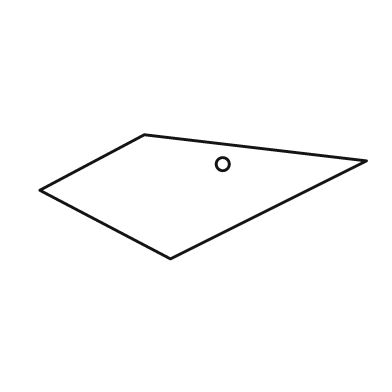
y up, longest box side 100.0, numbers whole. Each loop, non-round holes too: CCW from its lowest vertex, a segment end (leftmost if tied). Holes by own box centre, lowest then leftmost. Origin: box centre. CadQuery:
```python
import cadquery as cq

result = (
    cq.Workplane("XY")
    .moveTo(-10.0, -19.0)
    .lineTo(50.0, 11.0)
    .lineTo(-18.0, 19.0)
    .lineTo(-50.0, 2.0)
    .close()
    .moveTo(6.0, 10.0)
    .circle(2.0)
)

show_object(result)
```